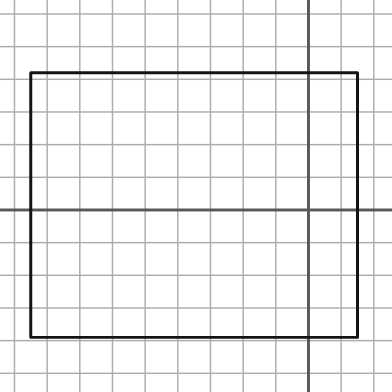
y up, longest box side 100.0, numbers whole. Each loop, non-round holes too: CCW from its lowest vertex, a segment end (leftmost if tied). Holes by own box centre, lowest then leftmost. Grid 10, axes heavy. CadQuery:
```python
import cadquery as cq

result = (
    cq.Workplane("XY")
    .moveTo(-85.0, -39.0)
    .lineTo(15.0, -39.0)
    .lineTo(15.0, 42.0)
    .lineTo(-85.0, 42.0)
    .close()
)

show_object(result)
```